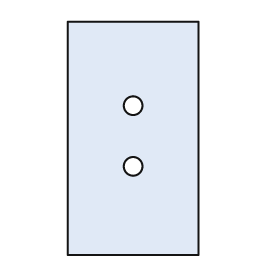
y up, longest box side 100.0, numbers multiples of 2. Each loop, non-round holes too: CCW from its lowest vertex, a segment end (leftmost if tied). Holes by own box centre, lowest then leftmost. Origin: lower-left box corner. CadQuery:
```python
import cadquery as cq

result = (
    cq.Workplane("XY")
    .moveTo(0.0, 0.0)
    .lineTo(56.0, 0.0)
    .lineTo(56.0, 100.0)
    .lineTo(0.0, 100.0)
    .close()
    .moveTo(28.0, 38.0)
    .circle(4.0)
    .moveTo(28.0, 64.0)
    .circle(4.0)
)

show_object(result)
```